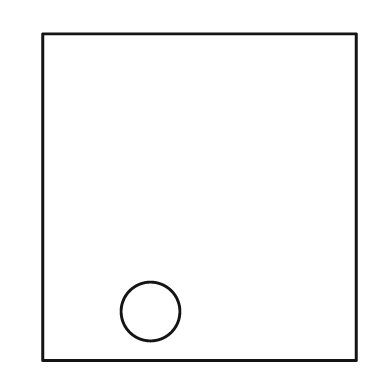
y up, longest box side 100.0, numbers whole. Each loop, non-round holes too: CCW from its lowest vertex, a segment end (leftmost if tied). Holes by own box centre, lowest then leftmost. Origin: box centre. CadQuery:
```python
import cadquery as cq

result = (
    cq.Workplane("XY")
    .moveTo(-48.0, -50.0)
    .lineTo(48.0, -50.0)
    .lineTo(48.0, 50.0)
    .lineTo(-48.0, 50.0)
    .close()
    .moveTo(-15.0, -35.0)
    .circle(9.0)
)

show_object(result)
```